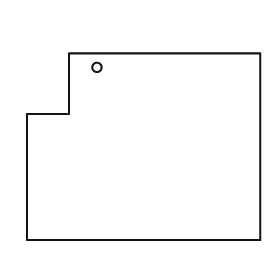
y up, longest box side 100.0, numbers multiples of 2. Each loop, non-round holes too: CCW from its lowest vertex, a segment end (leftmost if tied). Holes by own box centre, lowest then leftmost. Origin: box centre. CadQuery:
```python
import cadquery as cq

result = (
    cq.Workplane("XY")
    .moveTo(-50.0, -40.0)
    .lineTo(50.0, -40.0)
    .lineTo(50.0, 40.0)
    .lineTo(-32.0, 40.0)
    .lineTo(-32.0, 14.0)
    .lineTo(-50.0, 14.0)
    .close()
    .moveTo(-20.0, 34.0)
    .circle(2.0)
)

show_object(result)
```